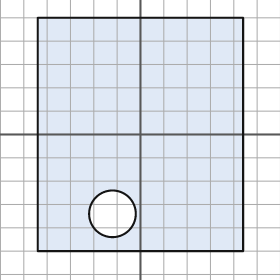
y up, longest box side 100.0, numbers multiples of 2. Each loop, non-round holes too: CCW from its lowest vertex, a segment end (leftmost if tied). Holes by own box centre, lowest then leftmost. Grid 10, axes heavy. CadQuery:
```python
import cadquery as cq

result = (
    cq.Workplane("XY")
    .moveTo(-44.0, -50.0)
    .lineTo(44.0, -50.0)
    .lineTo(44.0, 50.0)
    .lineTo(-44.0, 50.0)
    .close()
    .moveTo(-12.0, -34.0)
    .circle(10.0)
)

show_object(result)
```